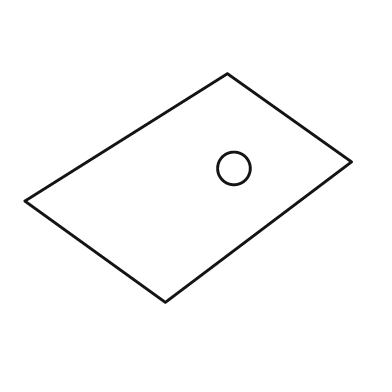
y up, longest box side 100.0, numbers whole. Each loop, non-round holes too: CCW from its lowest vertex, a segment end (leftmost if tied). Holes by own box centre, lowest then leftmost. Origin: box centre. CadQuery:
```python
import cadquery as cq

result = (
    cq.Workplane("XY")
    .moveTo(-7.0, -35.0)
    .lineTo(50.0, 8.0)
    .lineTo(12.0, 35.0)
    .lineTo(-50.0, -4.0)
    .close()
    .moveTo(14.0, 6.0)
    .circle(5.0)
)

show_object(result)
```